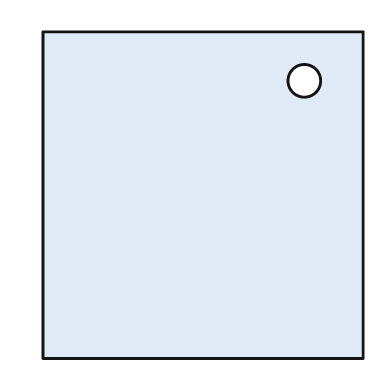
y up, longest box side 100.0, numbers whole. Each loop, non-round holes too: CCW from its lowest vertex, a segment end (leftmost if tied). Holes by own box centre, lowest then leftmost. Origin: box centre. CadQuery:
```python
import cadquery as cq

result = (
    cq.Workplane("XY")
    .moveTo(-49.0, -50.0)
    .lineTo(49.0, -50.0)
    .lineTo(49.0, 50.0)
    .lineTo(-49.0, 50.0)
    .close()
    .moveTo(31.0, 35.0)
    .circle(5.0)
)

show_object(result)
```